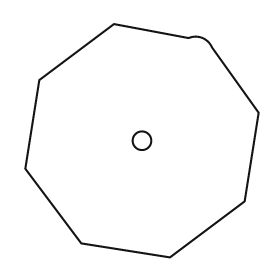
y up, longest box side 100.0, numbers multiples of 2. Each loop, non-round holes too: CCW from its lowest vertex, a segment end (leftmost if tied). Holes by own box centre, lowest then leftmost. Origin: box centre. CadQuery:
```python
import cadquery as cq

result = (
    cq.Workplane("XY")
    .moveTo(12.0, -50.0)
    .lineTo(44.0, -26.0)
    .lineTo(50.0, 12.0)
    .lineTo(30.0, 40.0)
    .threePointArc((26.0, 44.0), (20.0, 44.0))
    .lineTo(-12.0, 50.0)
    .lineTo(-44.0, 26.0)
    .lineTo(-50.0, -12.0)
    .lineTo(-26.0, -44.0)
    .close()
    .moveTo(0.0, 0.0)
    .circle(4.0)
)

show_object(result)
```